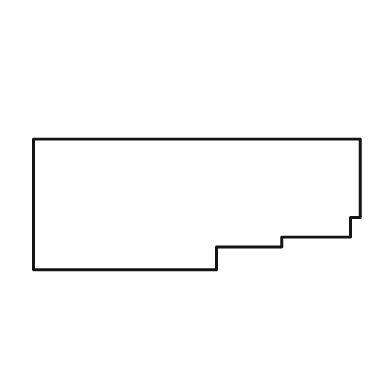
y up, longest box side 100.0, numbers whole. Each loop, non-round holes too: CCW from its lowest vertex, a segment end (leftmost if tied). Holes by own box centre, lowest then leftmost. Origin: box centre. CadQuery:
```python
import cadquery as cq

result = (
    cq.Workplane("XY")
    .moveTo(-50.0, -20.0)
    .lineTo(6.0, -20.0)
    .lineTo(6.0, -13.0)
    .lineTo(26.0, -13.0)
    .lineTo(26.0, -10.0)
    .lineTo(47.0, -10.0)
    .lineTo(47.0, -4.0)
    .lineTo(50.0, -4.0)
    .lineTo(50.0, 20.0)
    .lineTo(-50.0, 20.0)
    .close()
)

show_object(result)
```